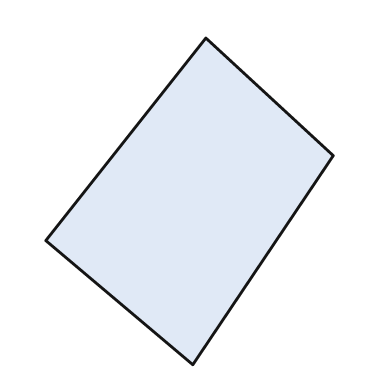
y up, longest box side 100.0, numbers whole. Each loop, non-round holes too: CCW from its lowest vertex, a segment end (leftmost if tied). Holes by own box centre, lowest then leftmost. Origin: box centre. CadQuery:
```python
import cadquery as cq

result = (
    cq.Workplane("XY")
    .moveTo(1.0, -50.0)
    .lineTo(44.0, 14.0)
    .lineTo(5.0, 50.0)
    .lineTo(-44.0, -12.0)
    .close()
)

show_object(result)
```